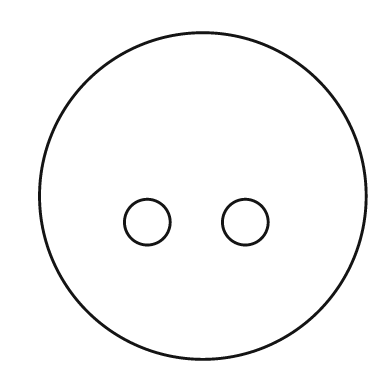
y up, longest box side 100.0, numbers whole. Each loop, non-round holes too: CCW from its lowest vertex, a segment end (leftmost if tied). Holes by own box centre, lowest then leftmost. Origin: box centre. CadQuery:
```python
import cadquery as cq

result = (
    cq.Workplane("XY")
    .moveTo(0.0, 0.0)
    .circle(50.0)
    .moveTo(-17.0, -8.0)
    .circle(7.0)
    .moveTo(13.0, -8.0)
    .circle(7.0)
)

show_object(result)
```